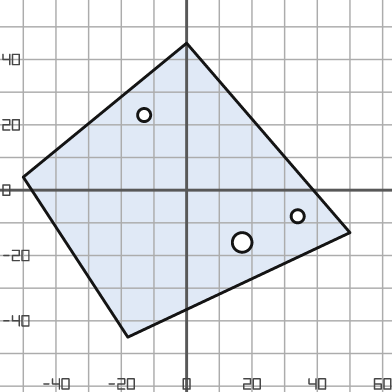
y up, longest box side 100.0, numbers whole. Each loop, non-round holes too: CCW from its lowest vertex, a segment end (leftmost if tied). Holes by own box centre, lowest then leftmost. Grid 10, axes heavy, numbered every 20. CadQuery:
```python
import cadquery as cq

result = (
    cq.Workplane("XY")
    .moveTo(-18.0, -45.0)
    .lineTo(50.0, -13.0)
    .lineTo(0.0, 45.0)
    .lineTo(-50.0, 4.0)
    .close()
    .moveTo(17.0, -16.0)
    .circle(3.0)
    .moveTo(34.0, -8.0)
    .circle(2.0)
    .moveTo(-13.0, 23.0)
    .circle(2.0)
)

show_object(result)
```